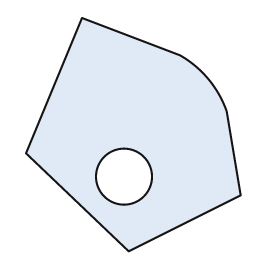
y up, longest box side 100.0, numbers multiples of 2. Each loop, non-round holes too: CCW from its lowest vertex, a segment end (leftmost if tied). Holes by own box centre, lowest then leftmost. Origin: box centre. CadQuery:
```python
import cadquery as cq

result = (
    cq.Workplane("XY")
    .moveTo(-2.0, -50.0)
    .lineTo(46.0, -26.0)
    .lineTo(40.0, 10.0)
    .threePointArc((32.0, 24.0), (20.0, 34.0))
    .lineTo(-22.0, 50.0)
    .lineTo(-46.0, -8.0)
    .close()
    .moveTo(-4.0, -18.0)
    .circle(12.0)
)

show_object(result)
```